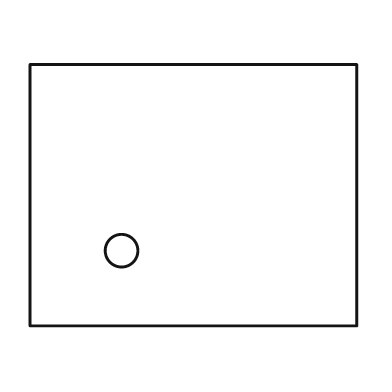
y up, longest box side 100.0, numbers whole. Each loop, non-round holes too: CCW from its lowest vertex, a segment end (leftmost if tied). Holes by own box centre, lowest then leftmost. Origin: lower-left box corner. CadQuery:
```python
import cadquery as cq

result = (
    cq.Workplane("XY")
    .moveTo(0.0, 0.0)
    .lineTo(100.0, 0.0)
    .lineTo(100.0, 80.0)
    .lineTo(0.0, 80.0)
    .close()
    .moveTo(28.0, 23.0)
    .circle(5.0)
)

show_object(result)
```